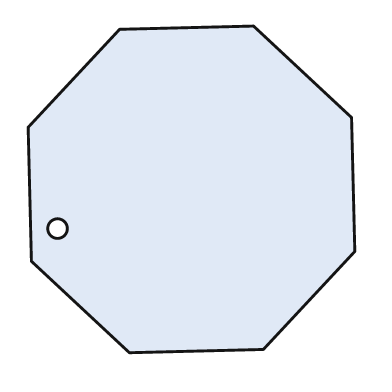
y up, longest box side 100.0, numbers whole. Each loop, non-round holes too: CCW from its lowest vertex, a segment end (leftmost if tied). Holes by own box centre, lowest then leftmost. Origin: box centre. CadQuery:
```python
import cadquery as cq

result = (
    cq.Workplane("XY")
    .moveTo(-19.0, -50.0)
    .lineTo(22.0, -49.0)
    .lineTo(50.0, -19.0)
    .lineTo(49.0, 22.0)
    .lineTo(19.0, 50.0)
    .lineTo(-22.0, 49.0)
    .lineTo(-50.0, 19.0)
    .lineTo(-49.0, -22.0)
    .close()
    .moveTo(-41.0, -12.0)
    .circle(3.0)
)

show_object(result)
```